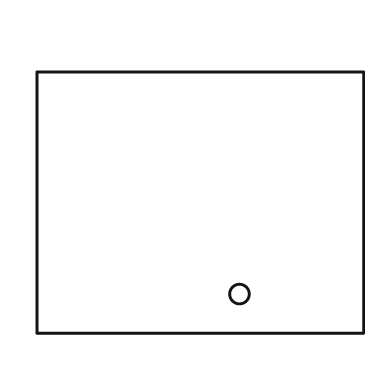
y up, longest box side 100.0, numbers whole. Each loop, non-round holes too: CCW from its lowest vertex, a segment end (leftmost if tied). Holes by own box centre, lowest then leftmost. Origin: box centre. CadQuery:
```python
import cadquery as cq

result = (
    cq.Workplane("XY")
    .moveTo(-50.0, -40.0)
    .lineTo(50.0, -40.0)
    .lineTo(50.0, 40.0)
    .lineTo(-50.0, 40.0)
    .close()
    .moveTo(12.0, -28.0)
    .circle(3.0)
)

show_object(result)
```